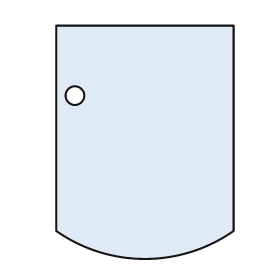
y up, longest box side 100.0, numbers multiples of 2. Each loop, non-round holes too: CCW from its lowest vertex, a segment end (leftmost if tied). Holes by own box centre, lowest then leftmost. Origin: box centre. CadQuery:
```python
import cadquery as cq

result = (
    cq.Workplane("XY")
    .moveTo(-38.0, -38.0)
    .threePointArc((0.0, -50.0), (38.0, -38.0))
    .lineTo(38.0, 50.0)
    .lineTo(-38.0, 50.0)
    .close()
    .moveTo(-30.0, 20.0)
    .circle(4.0)
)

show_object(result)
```